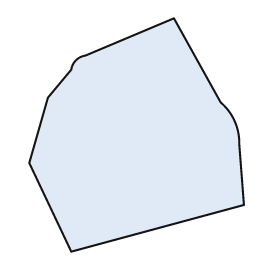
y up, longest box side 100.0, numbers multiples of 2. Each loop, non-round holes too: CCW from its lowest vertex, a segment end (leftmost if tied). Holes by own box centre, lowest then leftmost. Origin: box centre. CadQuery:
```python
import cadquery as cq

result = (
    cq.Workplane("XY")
    .moveTo(-28.0, -50.0)
    .lineTo(46.0, -30.0)
    .lineTo(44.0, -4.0)
    .threePointArc((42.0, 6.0), (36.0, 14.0))
    .lineTo(16.0, 50.0)
    .lineTo(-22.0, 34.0)
    .threePointArc((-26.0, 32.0), (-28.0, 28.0))
    .lineTo(-38.0, 16.0)
    .lineTo(-46.0, -12.0)
    .close()
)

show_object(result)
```